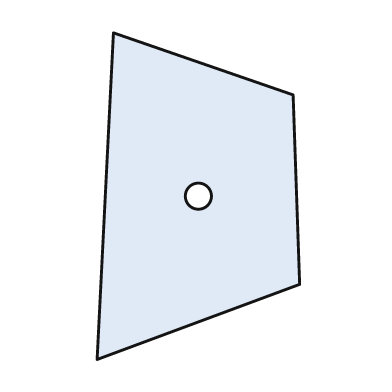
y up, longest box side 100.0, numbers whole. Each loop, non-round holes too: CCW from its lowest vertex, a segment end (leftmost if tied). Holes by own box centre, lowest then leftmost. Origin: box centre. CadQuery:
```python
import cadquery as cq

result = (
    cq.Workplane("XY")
    .moveTo(-31.0, -50.0)
    .lineTo(31.0, -27.0)
    .lineTo(29.0, 31.0)
    .lineTo(-26.0, 50.0)
    .close()
    .moveTo(0.0, 0.0)
    .circle(4.0)
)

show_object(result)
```